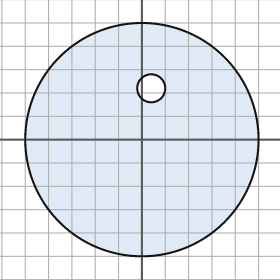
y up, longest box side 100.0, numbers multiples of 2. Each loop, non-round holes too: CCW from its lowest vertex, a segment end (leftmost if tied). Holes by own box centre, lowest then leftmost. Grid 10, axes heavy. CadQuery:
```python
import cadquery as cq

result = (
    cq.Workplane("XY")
    .moveTo(0.0, 0.0)
    .circle(50.0)
    .moveTo(4.0, 22.0)
    .circle(6.0)
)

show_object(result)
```